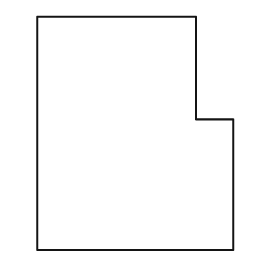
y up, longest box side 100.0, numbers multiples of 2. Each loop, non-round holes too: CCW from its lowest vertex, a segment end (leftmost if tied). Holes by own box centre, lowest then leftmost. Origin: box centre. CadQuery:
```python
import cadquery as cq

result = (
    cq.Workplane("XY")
    .moveTo(-42.0, -50.0)
    .lineTo(42.0, -50.0)
    .lineTo(42.0, 6.0)
    .lineTo(26.0, 6.0)
    .lineTo(26.0, 50.0)
    .lineTo(-42.0, 50.0)
    .close()
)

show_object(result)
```